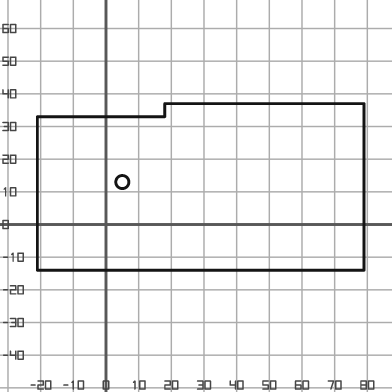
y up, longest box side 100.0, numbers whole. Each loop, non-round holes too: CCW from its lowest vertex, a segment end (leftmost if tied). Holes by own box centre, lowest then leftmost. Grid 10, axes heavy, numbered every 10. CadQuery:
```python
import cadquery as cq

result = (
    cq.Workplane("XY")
    .moveTo(-21.0, -14.0)
    .lineTo(79.0, -14.0)
    .lineTo(79.0, 37.0)
    .lineTo(18.0, 37.0)
    .lineTo(18.0, 33.0)
    .lineTo(-21.0, 33.0)
    .close()
    .moveTo(5.0, 13.0)
    .circle(2.0)
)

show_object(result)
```